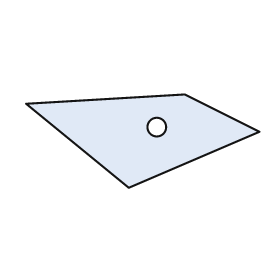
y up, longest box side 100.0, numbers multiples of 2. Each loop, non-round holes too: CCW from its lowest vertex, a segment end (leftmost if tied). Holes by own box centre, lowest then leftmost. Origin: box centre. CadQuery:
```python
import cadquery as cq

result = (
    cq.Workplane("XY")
    .moveTo(-6.0, -20.0)
    .lineTo(50.0, 4.0)
    .lineTo(18.0, 20.0)
    .lineTo(-50.0, 16.0)
    .close()
    .moveTo(6.0, 6.0)
    .circle(4.0)
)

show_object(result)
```